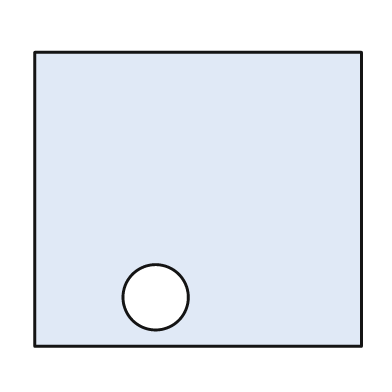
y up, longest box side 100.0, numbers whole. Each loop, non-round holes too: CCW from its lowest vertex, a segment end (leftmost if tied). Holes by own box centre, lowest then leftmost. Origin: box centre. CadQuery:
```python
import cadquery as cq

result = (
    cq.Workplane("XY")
    .moveTo(-50.0, -45.0)
    .lineTo(50.0, -45.0)
    .lineTo(50.0, 45.0)
    .lineTo(-50.0, 45.0)
    .close()
    .moveTo(-13.0, -30.0)
    .circle(10.0)
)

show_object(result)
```